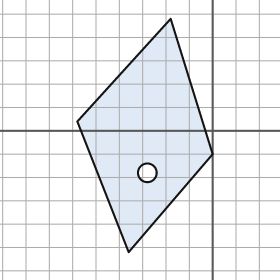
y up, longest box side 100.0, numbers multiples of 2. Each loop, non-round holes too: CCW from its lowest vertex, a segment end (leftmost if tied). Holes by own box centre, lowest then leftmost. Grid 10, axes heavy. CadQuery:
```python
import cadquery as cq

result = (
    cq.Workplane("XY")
    .moveTo(-36.0, -52.0)
    .lineTo(0.0, -10.0)
    .lineTo(-18.0, 48.0)
    .lineTo(-58.0, 4.0)
    .close()
    .moveTo(-28.0, -18.0)
    .circle(4.0)
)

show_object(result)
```